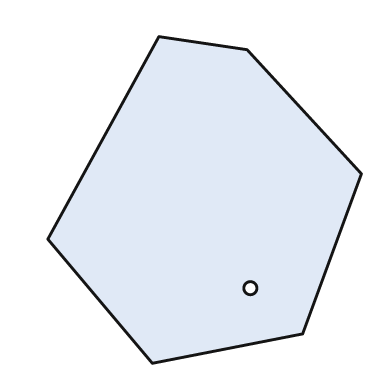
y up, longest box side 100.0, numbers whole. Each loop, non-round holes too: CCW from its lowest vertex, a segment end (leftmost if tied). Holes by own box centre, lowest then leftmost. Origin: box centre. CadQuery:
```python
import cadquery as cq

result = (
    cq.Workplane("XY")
    .moveTo(-16.0, -50.0)
    .lineTo(30.0, -41.0)
    .lineTo(48.0, 8.0)
    .lineTo(13.0, 46.0)
    .lineTo(-14.0, 50.0)
    .lineTo(-48.0, -12.0)
    .close()
    .moveTo(14.0, -27.0)
    .circle(2.0)
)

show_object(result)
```